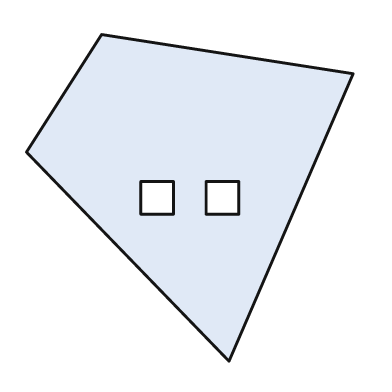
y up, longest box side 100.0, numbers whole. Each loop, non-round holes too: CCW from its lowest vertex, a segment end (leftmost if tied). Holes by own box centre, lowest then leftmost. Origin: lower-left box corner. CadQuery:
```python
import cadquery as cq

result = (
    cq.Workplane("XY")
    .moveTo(62.0, 0.0)
    .lineTo(100.0, 88.0)
    .lineTo(23.0, 100.0)
    .lineTo(0.0, 64.0)
    .close()
    .moveTo(35.0, 45.0)
    .lineTo(45.0, 45.0)
    .lineTo(45.0, 55.0)
    .lineTo(35.0, 55.0)
    .close()
    .moveTo(55.0, 45.0)
    .lineTo(65.0, 45.0)
    .lineTo(65.0, 55.0)
    .lineTo(55.0, 55.0)
    .close()
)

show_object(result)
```